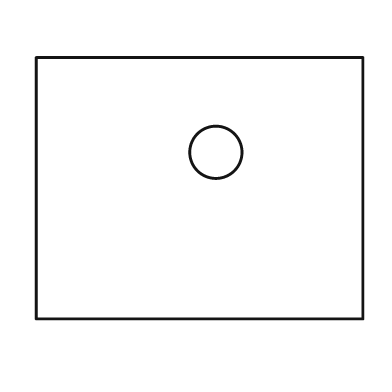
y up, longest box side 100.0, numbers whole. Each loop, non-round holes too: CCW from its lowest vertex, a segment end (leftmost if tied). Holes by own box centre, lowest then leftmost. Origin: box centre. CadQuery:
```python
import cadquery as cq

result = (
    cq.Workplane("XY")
    .moveTo(-50.0, -40.0)
    .lineTo(50.0, -40.0)
    .lineTo(50.0, 40.0)
    .lineTo(-50.0, 40.0)
    .close()
    .moveTo(5.0, 11.0)
    .circle(8.0)
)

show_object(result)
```